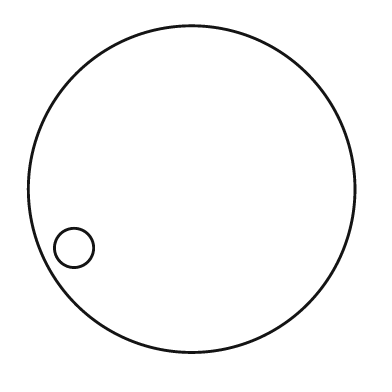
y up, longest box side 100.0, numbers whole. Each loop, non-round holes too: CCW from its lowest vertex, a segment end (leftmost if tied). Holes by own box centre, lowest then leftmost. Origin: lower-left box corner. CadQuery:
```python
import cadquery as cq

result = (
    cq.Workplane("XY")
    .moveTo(50.0, 50.0)
    .circle(50.0)
    .moveTo(14.0, 32.0)
    .circle(6.0)
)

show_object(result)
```